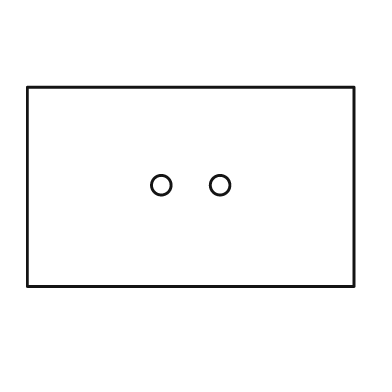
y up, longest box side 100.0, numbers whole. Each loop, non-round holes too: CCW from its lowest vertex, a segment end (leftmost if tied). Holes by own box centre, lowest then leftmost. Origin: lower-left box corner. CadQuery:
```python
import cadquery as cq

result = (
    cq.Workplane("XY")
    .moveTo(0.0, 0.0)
    .lineTo(100.0, 0.0)
    .lineTo(100.0, 61.0)
    .lineTo(0.0, 61.0)
    .close()
    .moveTo(41.0, 31.0)
    .circle(3.0)
    .moveTo(59.0, 31.0)
    .circle(3.0)
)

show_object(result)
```